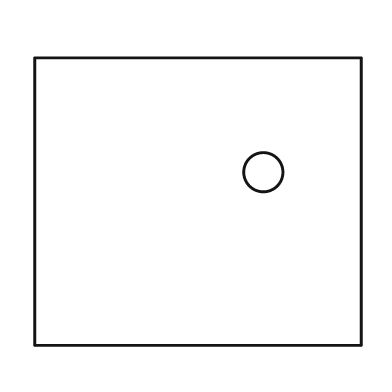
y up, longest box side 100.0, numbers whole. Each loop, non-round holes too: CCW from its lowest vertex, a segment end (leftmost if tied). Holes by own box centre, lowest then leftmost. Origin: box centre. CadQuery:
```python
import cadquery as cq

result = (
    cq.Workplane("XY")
    .moveTo(-50.0, -44.0)
    .lineTo(50.0, -44.0)
    .lineTo(50.0, 44.0)
    .lineTo(-50.0, 44.0)
    .close()
    .moveTo(20.0, 9.0)
    .circle(6.0)
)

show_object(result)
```